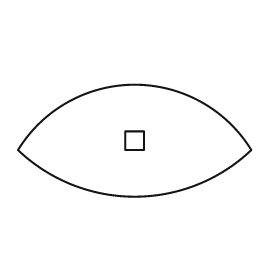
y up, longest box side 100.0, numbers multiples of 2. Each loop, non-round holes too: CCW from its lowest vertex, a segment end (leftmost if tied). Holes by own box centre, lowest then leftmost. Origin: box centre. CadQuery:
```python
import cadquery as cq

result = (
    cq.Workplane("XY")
    .moveTo(-50.0, -4.0)
    .threePointArc((0.0, -24.0), (50.0, -4.0))
    .threePointArc((0.0, 24.0), (-50.0, -4.0))
    .close()
    .moveTo(-4.0, -4.0)
    .lineTo(4.0, -4.0)
    .lineTo(4.0, 4.0)
    .lineTo(-4.0, 4.0)
    .close()
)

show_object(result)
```